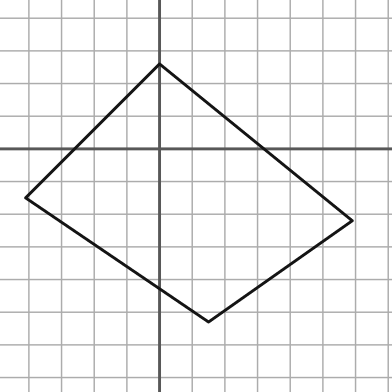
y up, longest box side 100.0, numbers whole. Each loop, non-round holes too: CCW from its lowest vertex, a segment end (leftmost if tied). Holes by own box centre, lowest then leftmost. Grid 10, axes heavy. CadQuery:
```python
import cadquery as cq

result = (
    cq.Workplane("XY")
    .moveTo(15.0, -53.0)
    .lineTo(59.0, -22.0)
    .lineTo(0.0, 26.0)
    .lineTo(-41.0, -15.0)
    .close()
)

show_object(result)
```